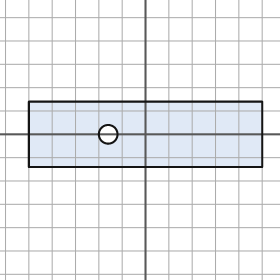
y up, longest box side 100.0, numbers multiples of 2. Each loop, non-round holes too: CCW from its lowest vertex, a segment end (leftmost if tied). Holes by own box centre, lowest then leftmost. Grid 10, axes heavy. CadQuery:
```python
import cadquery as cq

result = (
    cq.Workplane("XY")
    .moveTo(-50.0, -14.0)
    .lineTo(50.0, -14.0)
    .lineTo(50.0, 14.0)
    .lineTo(-50.0, 14.0)
    .close()
    .moveTo(-16.0, 0.0)
    .circle(4.0)
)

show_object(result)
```